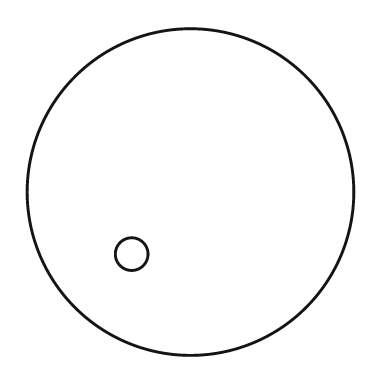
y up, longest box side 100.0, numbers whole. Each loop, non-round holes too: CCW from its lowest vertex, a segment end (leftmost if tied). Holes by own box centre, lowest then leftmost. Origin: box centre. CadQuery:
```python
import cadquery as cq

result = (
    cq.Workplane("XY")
    .moveTo(0.0, 0.0)
    .circle(50.0)
    .moveTo(-18.0, -19.0)
    .circle(5.0)
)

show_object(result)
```